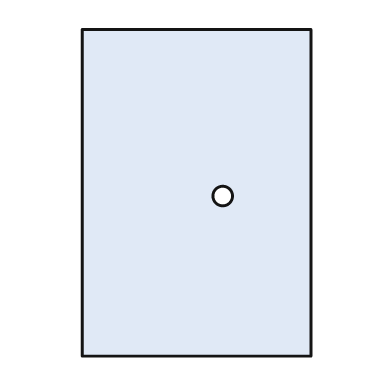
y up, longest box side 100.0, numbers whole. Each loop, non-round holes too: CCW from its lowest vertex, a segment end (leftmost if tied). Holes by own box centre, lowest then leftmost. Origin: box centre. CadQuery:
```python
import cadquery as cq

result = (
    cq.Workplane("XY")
    .moveTo(-35.0, -50.0)
    .lineTo(35.0, -50.0)
    .lineTo(35.0, 50.0)
    .lineTo(-35.0, 50.0)
    .close()
    .moveTo(8.0, -1.0)
    .circle(3.0)
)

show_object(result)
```